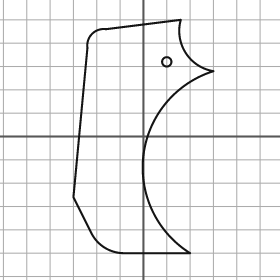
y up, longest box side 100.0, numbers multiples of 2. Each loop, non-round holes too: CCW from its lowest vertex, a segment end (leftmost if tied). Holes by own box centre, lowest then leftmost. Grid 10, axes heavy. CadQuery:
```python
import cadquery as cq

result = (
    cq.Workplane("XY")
    .moveTo(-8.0, -50.0)
    .lineTo(20.0, -50.0)
    .threePointArc((0.0, -8.0), (30.0, 28.0))
    .threePointArc((18.0, 36.0), (16.0, 50.0))
    .lineTo(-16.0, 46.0)
    .threePointArc((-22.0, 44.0), (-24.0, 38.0))
    .lineTo(-30.0, -26.0)
    .lineTo(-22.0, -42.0)
    .threePointArc((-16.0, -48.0), (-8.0, -50.0))
    .close()
    .moveTo(10.0, 32.0)
    .circle(2.0)
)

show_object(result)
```